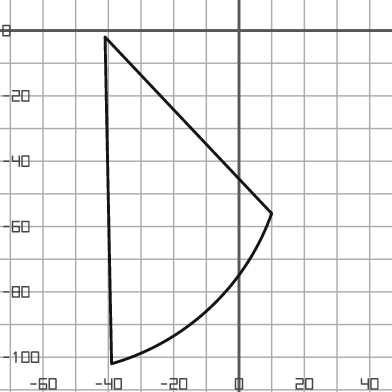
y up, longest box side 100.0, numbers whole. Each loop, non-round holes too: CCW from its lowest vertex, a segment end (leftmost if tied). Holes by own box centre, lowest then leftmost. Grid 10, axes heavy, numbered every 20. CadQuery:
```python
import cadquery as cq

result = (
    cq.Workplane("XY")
    .moveTo(-39.0, -102.0)
    .threePointArc((-9.0, -85.0), (10.0, -56.0))
    .lineTo(-41.0, -2.0)
    .close()
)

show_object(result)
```